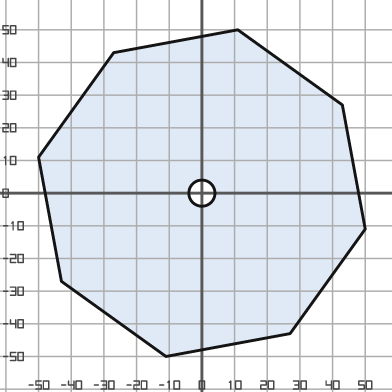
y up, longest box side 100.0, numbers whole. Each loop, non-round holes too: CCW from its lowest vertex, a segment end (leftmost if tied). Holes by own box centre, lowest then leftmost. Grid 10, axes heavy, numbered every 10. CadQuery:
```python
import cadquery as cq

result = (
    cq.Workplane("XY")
    .moveTo(-11.0, -50.0)
    .lineTo(27.0, -43.0)
    .lineTo(50.0, -11.0)
    .lineTo(43.0, 27.0)
    .lineTo(11.0, 50.0)
    .lineTo(-27.0, 43.0)
    .lineTo(-50.0, 11.0)
    .lineTo(-43.0, -27.0)
    .close()
    .moveTo(0.0, 0.0)
    .circle(4.0)
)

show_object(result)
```